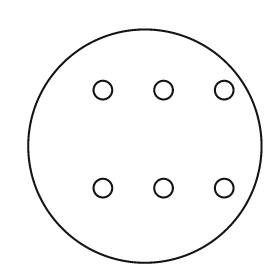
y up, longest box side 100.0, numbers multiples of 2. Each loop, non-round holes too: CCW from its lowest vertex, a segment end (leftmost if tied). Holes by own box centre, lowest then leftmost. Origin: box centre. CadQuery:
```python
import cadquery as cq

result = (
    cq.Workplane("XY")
    .moveTo(0.0, 0.0)
    .circle(50.0)
    .moveTo(-18.0, -18.0)
    .circle(4.0)
    .moveTo(8.0, -18.0)
    .circle(4.0)
    .moveTo(34.0, -18.0)
    .circle(4.0)
    .moveTo(-18.0, 24.0)
    .circle(4.0)
    .moveTo(8.0, 24.0)
    .circle(4.0)
    .moveTo(34.0, 24.0)
    .circle(4.0)
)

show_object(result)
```